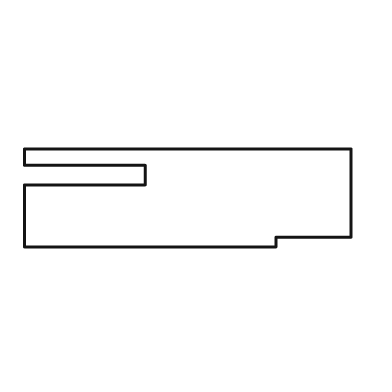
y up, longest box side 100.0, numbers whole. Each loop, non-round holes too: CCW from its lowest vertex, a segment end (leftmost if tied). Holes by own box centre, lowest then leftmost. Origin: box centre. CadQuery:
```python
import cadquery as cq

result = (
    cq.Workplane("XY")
    .moveTo(-50.0, -15.0)
    .lineTo(27.0, -15.0)
    .lineTo(27.0, -12.0)
    .lineTo(50.0, -12.0)
    .lineTo(50.0, 15.0)
    .lineTo(-50.0, 15.0)
    .lineTo(-50.0, 10.0)
    .lineTo(-13.0, 10.0)
    .lineTo(-13.0, 4.0)
    .lineTo(-50.0, 4.0)
    .close()
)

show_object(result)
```